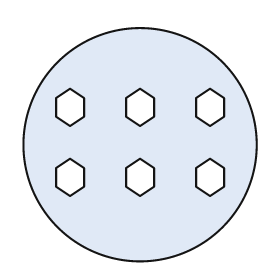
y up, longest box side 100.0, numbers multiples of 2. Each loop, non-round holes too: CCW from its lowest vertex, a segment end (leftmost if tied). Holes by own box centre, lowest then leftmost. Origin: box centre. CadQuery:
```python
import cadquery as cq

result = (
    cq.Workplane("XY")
    .moveTo(0.0, 0.0)
    .circle(50.0)
    .moveTo(-30.0, -22.0)
    .lineTo(-24.0, -18.0)
    .lineTo(-24.0, -10.0)
    .lineTo(-30.0, -6.0)
    .lineTo(-36.0, -10.0)
    .lineTo(-36.0, -18.0)
    .close()
    .moveTo(0.0, -22.0)
    .lineTo(6.0, -18.0)
    .lineTo(6.0, -10.0)
    .lineTo(0.0, -6.0)
    .lineTo(-6.0, -10.0)
    .lineTo(-6.0, -18.0)
    .close()
    .moveTo(30.0, -22.0)
    .lineTo(36.0, -18.0)
    .lineTo(36.0, -10.0)
    .lineTo(30.0, -6.0)
    .lineTo(24.0, -10.0)
    .lineTo(24.0, -18.0)
    .close()
    .moveTo(-30.0, 8.0)
    .lineTo(-24.0, 12.0)
    .lineTo(-24.0, 20.0)
    .lineTo(-30.0, 24.0)
    .lineTo(-36.0, 20.0)
    .lineTo(-36.0, 12.0)
    .close()
    .moveTo(0.0, 8.0)
    .lineTo(6.0, 12.0)
    .lineTo(6.0, 20.0)
    .lineTo(0.0, 24.0)
    .lineTo(-6.0, 20.0)
    .lineTo(-6.0, 12.0)
    .close()
    .moveTo(30.0, 8.0)
    .lineTo(36.0, 12.0)
    .lineTo(36.0, 20.0)
    .lineTo(30.0, 24.0)
    .lineTo(24.0, 20.0)
    .lineTo(24.0, 12.0)
    .close()
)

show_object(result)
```